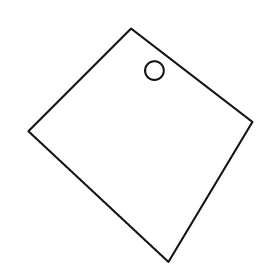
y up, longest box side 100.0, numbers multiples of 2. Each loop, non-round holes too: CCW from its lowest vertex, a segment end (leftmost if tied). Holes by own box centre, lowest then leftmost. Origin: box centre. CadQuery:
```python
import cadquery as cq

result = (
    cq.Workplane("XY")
    .moveTo(12.0, -50.0)
    .lineTo(48.0, 10.0)
    .lineTo(-4.0, 50.0)
    .lineTo(-48.0, 6.0)
    .close()
    .moveTo(6.0, 32.0)
    .circle(4.0)
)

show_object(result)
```